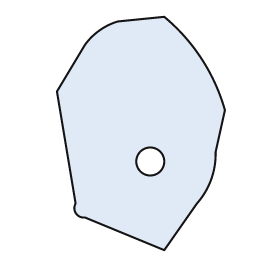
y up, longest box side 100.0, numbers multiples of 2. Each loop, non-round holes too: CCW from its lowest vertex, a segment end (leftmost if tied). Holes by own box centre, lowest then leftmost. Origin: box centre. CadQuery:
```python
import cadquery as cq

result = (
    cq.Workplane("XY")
    .moveTo(10.0, -50.0)
    .lineTo(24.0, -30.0)
    .threePointArc((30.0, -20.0), (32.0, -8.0))
    .lineTo(36.0, 10.0)
    .threePointArc((26.0, 32.0), (10.0, 50.0))
    .lineTo(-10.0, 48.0)
    .threePointArc((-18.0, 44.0), (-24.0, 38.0))
    .lineTo(-36.0, 18.0)
    .lineTo(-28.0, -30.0)
    .threePointArc((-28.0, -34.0), (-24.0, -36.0))
    .close()
    .moveTo(4.0, -12.0)
    .circle(6.0)
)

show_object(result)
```